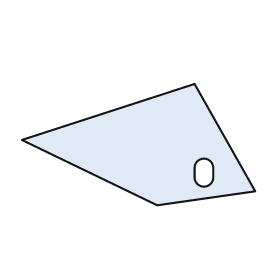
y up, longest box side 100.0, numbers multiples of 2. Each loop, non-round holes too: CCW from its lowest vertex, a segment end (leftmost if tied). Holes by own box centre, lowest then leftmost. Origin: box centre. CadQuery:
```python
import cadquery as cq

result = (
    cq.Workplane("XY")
    .moveTo(8.0, -26.0)
    .lineTo(50.0, -20.0)
    .lineTo(24.0, 26.0)
    .lineTo(-50.0, 2.0)
    .close()
    .moveTo(24.0, -14.0)
    .threePointArc((28.0, -18.0), (32.0, -14.0))
    .lineTo(32.0, -10.0)
    .threePointArc((28.0, -6.0), (24.0, -10.0))
    .close()
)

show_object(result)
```